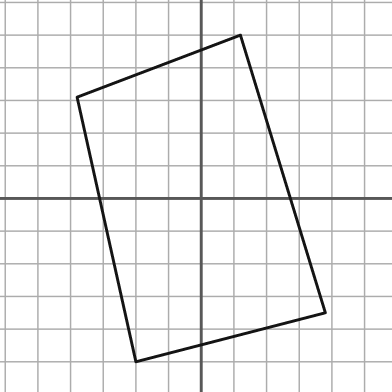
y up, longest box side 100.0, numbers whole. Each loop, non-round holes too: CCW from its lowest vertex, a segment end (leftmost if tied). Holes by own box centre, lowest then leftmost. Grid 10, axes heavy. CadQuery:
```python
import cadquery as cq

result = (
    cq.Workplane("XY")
    .moveTo(-20.0, -50.0)
    .lineTo(38.0, -35.0)
    .lineTo(12.0, 50.0)
    .lineTo(-38.0, 31.0)
    .close()
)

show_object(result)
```